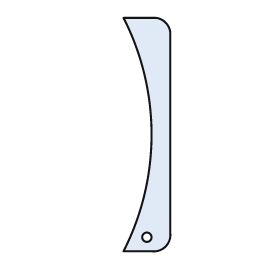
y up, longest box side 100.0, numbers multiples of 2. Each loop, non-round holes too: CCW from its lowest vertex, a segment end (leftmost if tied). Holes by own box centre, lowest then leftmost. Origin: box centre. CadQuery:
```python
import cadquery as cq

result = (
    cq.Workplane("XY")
    .moveTo(-10.0, -50.0)
    .lineTo(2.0, -50.0)
    .threePointArc((8.0, -48.0), (10.0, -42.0))
    .lineTo(10.0, 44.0)
    .threePointArc((8.0, 48.0), (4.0, 50.0))
    .lineTo(-10.0, 50.0)
    .threePointArc((2.0, 0.0), (-10.0, -50.0))
    .close()
    .moveTo(0.0, -44.0)
    .circle(2.0)
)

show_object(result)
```